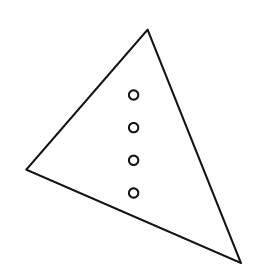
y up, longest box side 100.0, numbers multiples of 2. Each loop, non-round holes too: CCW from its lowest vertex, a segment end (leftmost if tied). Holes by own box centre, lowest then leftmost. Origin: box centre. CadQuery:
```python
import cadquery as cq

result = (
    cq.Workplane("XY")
    .moveTo(46.0, -50.0)
    .lineTo(6.0, 50.0)
    .lineTo(-46.0, -10.0)
    .close()
    .moveTo(0.0, -20.0)
    .circle(2.0)
    .moveTo(0.0, -6.0)
    .circle(2.0)
    .moveTo(0.0, 8.0)
    .circle(2.0)
    .moveTo(0.0, 22.0)
    .circle(2.0)
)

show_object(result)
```